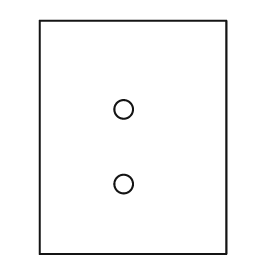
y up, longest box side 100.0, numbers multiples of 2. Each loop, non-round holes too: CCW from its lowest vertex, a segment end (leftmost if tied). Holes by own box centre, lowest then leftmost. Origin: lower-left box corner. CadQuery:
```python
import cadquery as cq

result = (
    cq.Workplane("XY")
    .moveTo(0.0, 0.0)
    .lineTo(80.0, 0.0)
    .lineTo(80.0, 100.0)
    .lineTo(0.0, 100.0)
    .close()
    .moveTo(36.0, 30.0)
    .circle(4.0)
    .moveTo(36.0, 62.0)
    .circle(4.0)
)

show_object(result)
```